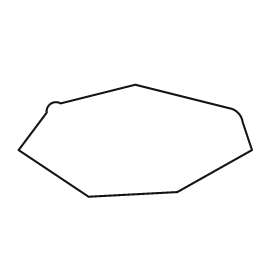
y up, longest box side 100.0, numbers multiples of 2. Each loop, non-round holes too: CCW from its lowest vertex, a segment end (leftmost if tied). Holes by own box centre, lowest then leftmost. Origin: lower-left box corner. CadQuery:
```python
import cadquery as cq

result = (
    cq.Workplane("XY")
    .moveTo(30.0, 0.0)
    .lineTo(68.0, 2.0)
    .lineTo(100.0, 20.0)
    .lineTo(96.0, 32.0)
    .threePointArc((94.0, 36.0), (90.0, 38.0))
    .lineTo(50.0, 48.0)
    .lineTo(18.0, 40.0)
    .threePointArc((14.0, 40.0), (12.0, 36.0))
    .lineTo(0.0, 20.0)
    .close()
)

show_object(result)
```